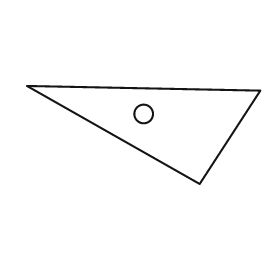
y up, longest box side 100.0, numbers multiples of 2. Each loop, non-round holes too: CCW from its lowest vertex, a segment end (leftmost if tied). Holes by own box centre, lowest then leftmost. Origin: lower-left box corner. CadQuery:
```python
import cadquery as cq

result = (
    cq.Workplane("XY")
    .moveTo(74.0, 0.0)
    .lineTo(100.0, 40.0)
    .lineTo(0.0, 42.0)
    .close()
    .moveTo(50.0, 30.0)
    .circle(4.0)
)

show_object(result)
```